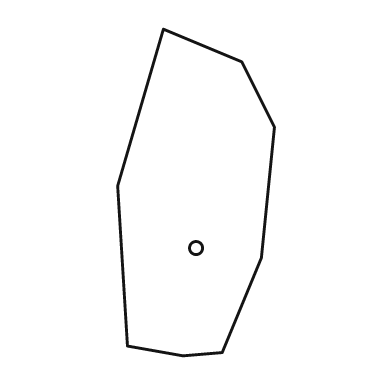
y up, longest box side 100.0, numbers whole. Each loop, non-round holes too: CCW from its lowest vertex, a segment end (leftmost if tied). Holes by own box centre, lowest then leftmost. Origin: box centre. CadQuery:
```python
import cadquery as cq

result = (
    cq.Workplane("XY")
    .moveTo(-4.0, -50.0)
    .lineTo(8.0, -49.0)
    .lineTo(20.0, -20.0)
    .lineTo(24.0, 20.0)
    .lineTo(14.0, 40.0)
    .lineTo(-10.0, 50.0)
    .lineTo(-24.0, 2.0)
    .lineTo(-21.0, -47.0)
    .close()
    .moveTo(0.0, -17.0)
    .circle(2.0)
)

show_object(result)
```